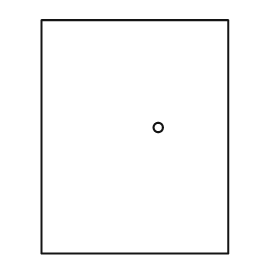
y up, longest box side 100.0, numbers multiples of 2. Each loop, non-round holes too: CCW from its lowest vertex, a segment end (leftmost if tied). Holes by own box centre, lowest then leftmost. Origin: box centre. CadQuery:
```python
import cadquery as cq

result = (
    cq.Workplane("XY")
    .moveTo(-40.0, -50.0)
    .lineTo(40.0, -50.0)
    .lineTo(40.0, 50.0)
    .lineTo(-40.0, 50.0)
    .close()
    .moveTo(10.0, 4.0)
    .circle(2.0)
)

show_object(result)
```